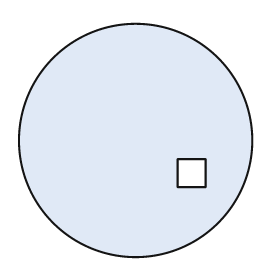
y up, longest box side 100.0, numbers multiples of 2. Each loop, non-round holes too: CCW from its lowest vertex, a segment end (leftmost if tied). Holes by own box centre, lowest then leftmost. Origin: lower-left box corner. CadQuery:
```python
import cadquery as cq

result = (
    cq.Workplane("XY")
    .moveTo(50.0, 50.0)
    .circle(50.0)
    .moveTo(68.0, 30.0)
    .lineTo(80.0, 30.0)
    .lineTo(80.0, 42.0)
    .lineTo(68.0, 42.0)
    .close()
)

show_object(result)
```